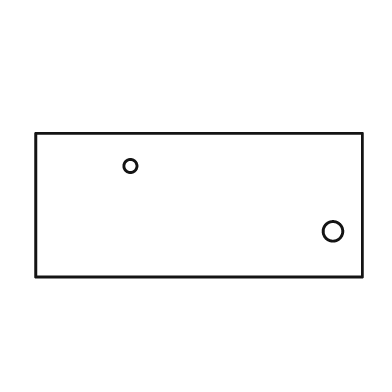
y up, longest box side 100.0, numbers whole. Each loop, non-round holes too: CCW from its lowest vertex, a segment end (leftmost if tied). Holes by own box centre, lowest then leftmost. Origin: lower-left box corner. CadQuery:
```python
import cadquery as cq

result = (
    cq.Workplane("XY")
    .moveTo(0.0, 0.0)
    .lineTo(100.0, 0.0)
    .lineTo(100.0, 44.0)
    .lineTo(0.0, 44.0)
    .close()
    .moveTo(91.0, 14.0)
    .circle(3.0)
    .moveTo(29.0, 34.0)
    .circle(2.0)
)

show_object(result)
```